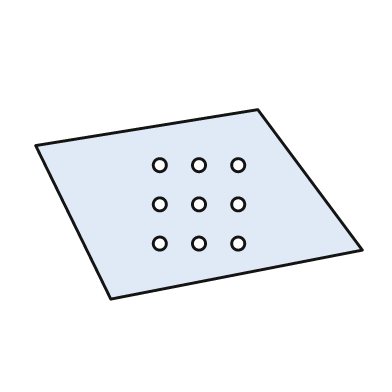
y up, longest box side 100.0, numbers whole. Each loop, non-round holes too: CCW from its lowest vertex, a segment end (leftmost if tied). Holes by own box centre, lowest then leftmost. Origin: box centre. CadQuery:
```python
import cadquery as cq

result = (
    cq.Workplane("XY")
    .moveTo(-27.0, -29.0)
    .lineTo(50.0, -14.0)
    .lineTo(18.0, 29.0)
    .lineTo(-50.0, 18.0)
    .close()
    .moveTo(-12.0, -12.0)
    .circle(2.0)
    .moveTo(0.0, -12.0)
    .circle(2.0)
    .moveTo(12.0, -12.0)
    .circle(2.0)
    .moveTo(-12.0, 0.0)
    .circle(2.0)
    .moveTo(0.0, 0.0)
    .circle(2.0)
    .moveTo(12.0, 0.0)
    .circle(2.0)
    .moveTo(-12.0, 12.0)
    .circle(2.0)
    .moveTo(0.0, 12.0)
    .circle(2.0)
    .moveTo(12.0, 12.0)
    .circle(2.0)
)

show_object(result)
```